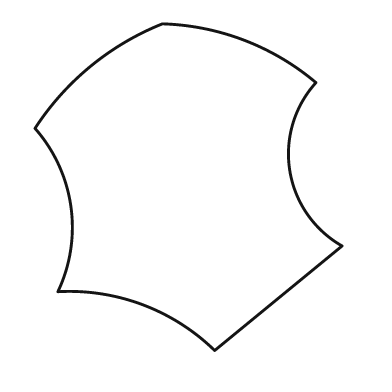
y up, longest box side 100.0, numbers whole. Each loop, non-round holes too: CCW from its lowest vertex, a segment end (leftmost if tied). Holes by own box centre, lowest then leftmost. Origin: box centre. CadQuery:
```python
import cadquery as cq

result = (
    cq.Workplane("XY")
    .moveTo(8.0, -50.0)
    .lineTo(47.0, -18.0)
    .threePointArc((31.0, 5.0), (39.0, 32.0))
    .threePointArc((17.0, 45.0), (-8.0, 50.0))
    .threePointArc((-30.0, 37.0), (-47.0, 18.0))
    .threePointArc((-36.0, -6.0), (-40.0, -32.0))
    .threePointArc((-14.0, -36.0), (8.0, -50.0))
    .close()
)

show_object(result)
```